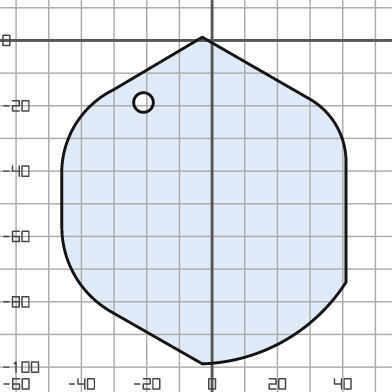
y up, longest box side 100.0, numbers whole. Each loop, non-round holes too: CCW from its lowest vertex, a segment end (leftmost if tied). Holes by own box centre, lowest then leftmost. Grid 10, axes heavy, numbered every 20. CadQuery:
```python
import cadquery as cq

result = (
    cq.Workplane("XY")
    .moveTo(-3.0, -99.0)
    .threePointArc((22.0, -92.0), (41.0, -74.0))
    .lineTo(41.0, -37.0)
    .threePointArc((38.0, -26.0), (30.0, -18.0))
    .lineTo(-3.0, 1.0)
    .lineTo(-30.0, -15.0)
    .threePointArc((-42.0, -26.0), (-46.0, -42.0))
    .lineTo(-46.0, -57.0)
    .threePointArc((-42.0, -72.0), (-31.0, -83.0))
    .close()
    .moveTo(-21.0, -19.0)
    .circle(3.0)
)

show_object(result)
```